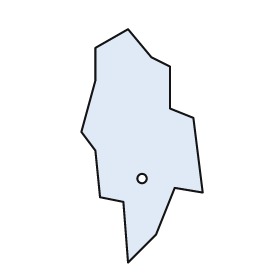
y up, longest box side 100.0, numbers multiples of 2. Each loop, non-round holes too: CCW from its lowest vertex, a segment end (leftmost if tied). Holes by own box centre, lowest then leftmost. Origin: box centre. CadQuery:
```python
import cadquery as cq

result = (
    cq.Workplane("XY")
    .moveTo(-6.0, -50.0)
    .lineTo(6.0, -38.0)
    .lineTo(14.0, -18.0)
    .lineTo(26.0, -20.0)
    .lineTo(22.0, 12.0)
    .lineTo(12.0, 16.0)
    .lineTo(12.0, 34.0)
    .lineTo(4.0, 38.0)
    .lineTo(-6.0, 50.0)
    .lineTo(-20.0, 42.0)
    .lineTo(-20.0, 28.0)
    .lineTo(-26.0, 6.0)
    .lineTo(-20.0, -2.0)
    .lineTo(-18.0, -22.0)
    .lineTo(-8.0, -24.0)
    .close()
    .moveTo(0.0, -14.0)
    .circle(2.0)
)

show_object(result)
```